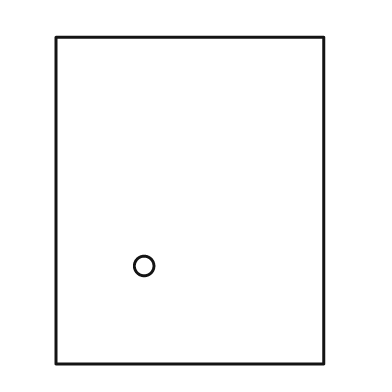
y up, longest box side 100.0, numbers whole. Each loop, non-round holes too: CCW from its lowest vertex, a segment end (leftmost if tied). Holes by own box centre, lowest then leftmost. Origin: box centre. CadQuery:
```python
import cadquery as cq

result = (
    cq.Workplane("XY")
    .moveTo(-41.0, -50.0)
    .lineTo(41.0, -50.0)
    .lineTo(41.0, 50.0)
    .lineTo(-41.0, 50.0)
    .close()
    .moveTo(-14.0, -20.0)
    .circle(3.0)
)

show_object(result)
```